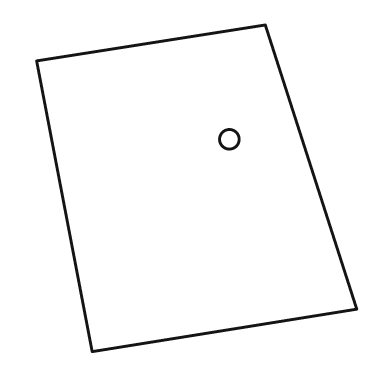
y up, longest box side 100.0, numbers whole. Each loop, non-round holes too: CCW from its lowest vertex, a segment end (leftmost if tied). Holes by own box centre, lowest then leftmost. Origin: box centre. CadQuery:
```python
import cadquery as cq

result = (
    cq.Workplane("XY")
    .moveTo(-32.0, -50.0)
    .lineTo(49.0, -37.0)
    .lineTo(21.0, 50.0)
    .lineTo(-49.0, 39.0)
    .close()
    .moveTo(10.0, 15.0)
    .circle(3.0)
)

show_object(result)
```